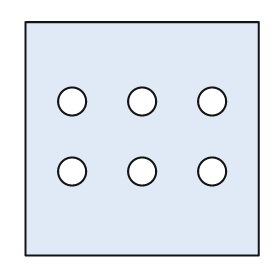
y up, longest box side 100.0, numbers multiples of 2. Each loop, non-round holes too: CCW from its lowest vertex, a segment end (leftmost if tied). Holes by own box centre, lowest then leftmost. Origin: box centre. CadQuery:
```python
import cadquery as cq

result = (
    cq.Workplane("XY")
    .moveTo(-50.0, -50.0)
    .lineTo(50.0, -50.0)
    .lineTo(50.0, 50.0)
    .lineTo(-50.0, 50.0)
    .close()
    .moveTo(-30.0, -14.0)
    .circle(6.0)
    .moveTo(0.0, -14.0)
    .circle(6.0)
    .moveTo(30.0, -14.0)
    .circle(6.0)
    .moveTo(-30.0, 16.0)
    .circle(6.0)
    .moveTo(0.0, 16.0)
    .circle(6.0)
    .moveTo(30.0, 16.0)
    .circle(6.0)
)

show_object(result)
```